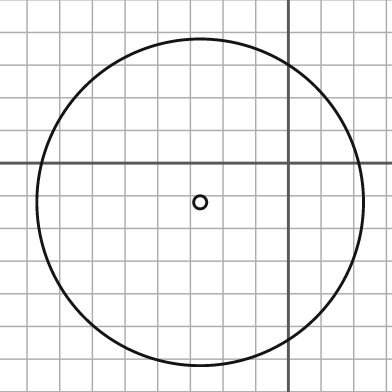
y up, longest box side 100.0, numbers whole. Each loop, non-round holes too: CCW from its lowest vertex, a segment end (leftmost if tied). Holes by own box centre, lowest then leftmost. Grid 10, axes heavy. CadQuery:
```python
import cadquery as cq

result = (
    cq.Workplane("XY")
    .moveTo(-27.0, -12.0)
    .circle(50.0)
    .moveTo(-27.0, -12.0)
    .circle(2.0)
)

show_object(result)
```